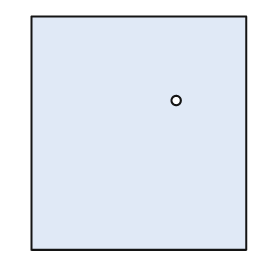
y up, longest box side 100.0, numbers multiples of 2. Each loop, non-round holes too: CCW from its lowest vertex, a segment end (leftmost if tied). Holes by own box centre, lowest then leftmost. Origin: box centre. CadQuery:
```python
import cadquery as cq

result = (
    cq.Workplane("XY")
    .moveTo(-46.0, -50.0)
    .lineTo(46.0, -50.0)
    .lineTo(46.0, 50.0)
    .lineTo(-46.0, 50.0)
    .close()
    .moveTo(16.0, 14.0)
    .circle(2.0)
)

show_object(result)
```